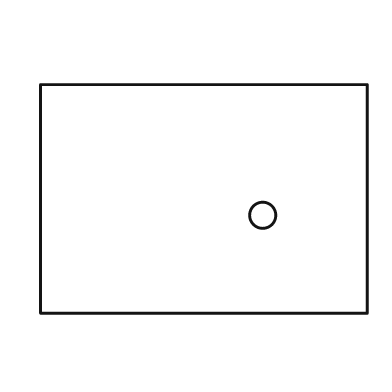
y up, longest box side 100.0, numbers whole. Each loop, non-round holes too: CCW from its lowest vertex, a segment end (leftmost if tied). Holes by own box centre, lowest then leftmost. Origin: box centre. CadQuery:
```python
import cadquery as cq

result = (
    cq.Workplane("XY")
    .moveTo(-50.0, -35.0)
    .lineTo(50.0, -35.0)
    .lineTo(50.0, 35.0)
    .lineTo(-50.0, 35.0)
    .close()
    .moveTo(18.0, -5.0)
    .circle(4.0)
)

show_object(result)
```